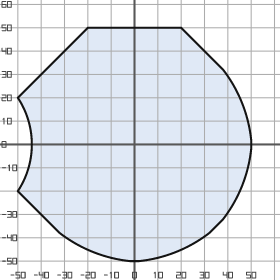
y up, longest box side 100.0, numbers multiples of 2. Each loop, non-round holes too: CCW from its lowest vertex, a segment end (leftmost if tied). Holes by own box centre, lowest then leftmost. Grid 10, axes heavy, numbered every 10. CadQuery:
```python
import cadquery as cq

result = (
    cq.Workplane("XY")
    .moveTo(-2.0, -50.0)
    .lineTo(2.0, -50.0)
    .threePointArc((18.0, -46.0), (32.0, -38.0))
    .lineTo(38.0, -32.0)
    .threePointArc((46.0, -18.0), (50.0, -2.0))
    .lineTo(50.0, 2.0)
    .threePointArc((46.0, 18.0), (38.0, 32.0))
    .lineTo(20.0, 50.0)
    .lineTo(-20.0, 50.0)
    .lineTo(-50.0, 20.0)
    .threePointArc((-44.0, 0.0), (-50.0, -20.0))
    .lineTo(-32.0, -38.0)
    .threePointArc((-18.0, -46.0), (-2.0, -50.0))
    .close()
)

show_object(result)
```